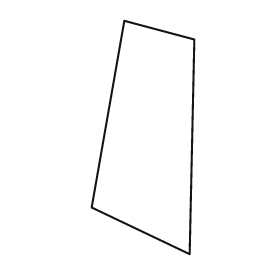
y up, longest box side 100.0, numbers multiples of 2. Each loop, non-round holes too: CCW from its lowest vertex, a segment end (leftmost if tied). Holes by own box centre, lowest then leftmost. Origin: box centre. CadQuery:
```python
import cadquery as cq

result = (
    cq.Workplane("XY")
    .moveTo(20.0, -50.0)
    .lineTo(22.0, 42.0)
    .lineTo(-8.0, 50.0)
    .lineTo(-22.0, -30.0)
    .close()
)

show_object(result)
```